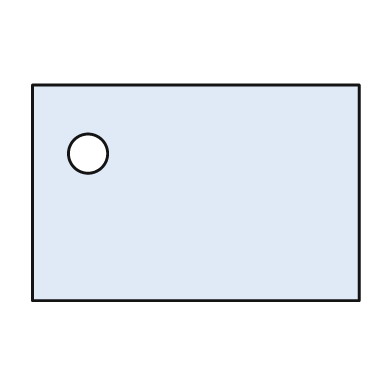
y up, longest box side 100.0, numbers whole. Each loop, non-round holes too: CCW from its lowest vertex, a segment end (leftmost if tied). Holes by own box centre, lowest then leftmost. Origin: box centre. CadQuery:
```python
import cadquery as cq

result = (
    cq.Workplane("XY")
    .moveTo(-50.0, -33.0)
    .lineTo(50.0, -33.0)
    .lineTo(50.0, 33.0)
    .lineTo(-50.0, 33.0)
    .close()
    .moveTo(-33.0, 12.0)
    .circle(6.0)
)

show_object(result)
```